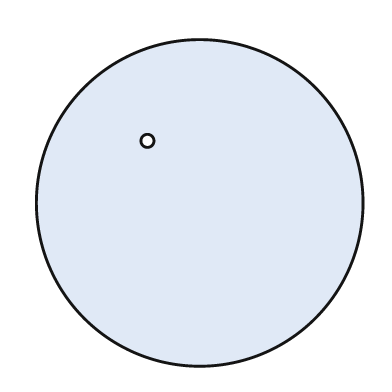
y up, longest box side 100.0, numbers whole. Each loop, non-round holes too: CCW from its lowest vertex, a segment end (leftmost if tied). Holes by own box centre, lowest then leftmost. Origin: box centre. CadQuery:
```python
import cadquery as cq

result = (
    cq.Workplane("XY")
    .moveTo(0.0, 0.0)
    .circle(50.0)
    .moveTo(-16.0, 19.0)
    .circle(2.0)
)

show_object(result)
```